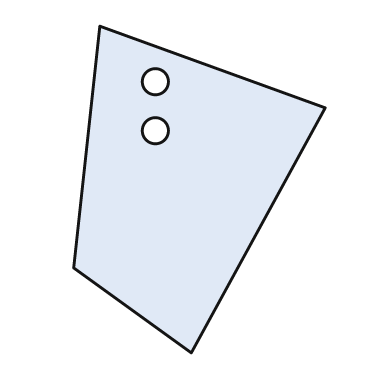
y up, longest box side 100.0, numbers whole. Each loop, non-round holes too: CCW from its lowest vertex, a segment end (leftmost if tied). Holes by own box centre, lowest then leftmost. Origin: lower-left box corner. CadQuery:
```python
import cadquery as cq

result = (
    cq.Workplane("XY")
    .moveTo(36.0, 0.0)
    .lineTo(77.0, 75.0)
    .lineTo(8.0, 100.0)
    .lineTo(0.0, 26.0)
    .close()
    .moveTo(25.0, 68.0)
    .circle(4.0)
    .moveTo(25.0, 83.0)
    .circle(4.0)
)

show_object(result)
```